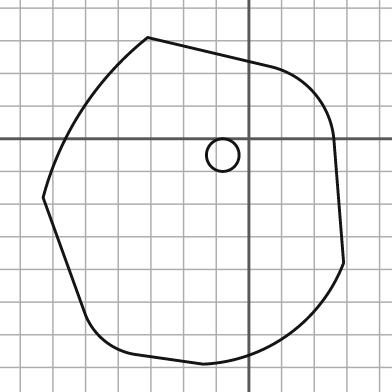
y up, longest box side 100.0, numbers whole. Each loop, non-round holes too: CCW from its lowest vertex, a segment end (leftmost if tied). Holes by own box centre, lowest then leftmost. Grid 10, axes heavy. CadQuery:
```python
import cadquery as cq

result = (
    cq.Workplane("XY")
    .moveTo(-14.0, -69.0)
    .threePointArc((12.0, -60.0), (29.0, -38.0))
    .lineTo(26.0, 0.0)
    .threePointArc((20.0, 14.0), (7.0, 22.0))
    .lineTo(-31.0, 31.0)
    .threePointArc((-51.0, 9.0), (-63.0, -18.0))
    .lineTo(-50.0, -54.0)
    .threePointArc((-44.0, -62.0), (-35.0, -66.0))
    .close()
    .moveTo(-8.0, -5.0)
    .circle(5.0)
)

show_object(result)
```